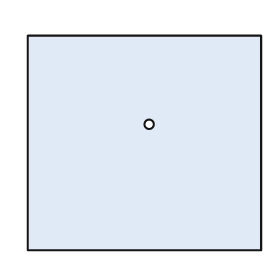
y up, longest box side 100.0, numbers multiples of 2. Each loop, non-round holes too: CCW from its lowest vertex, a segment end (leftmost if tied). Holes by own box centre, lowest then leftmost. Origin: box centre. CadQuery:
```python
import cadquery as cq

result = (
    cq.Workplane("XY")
    .moveTo(-50.0, -46.0)
    .lineTo(50.0, -46.0)
    .lineTo(50.0, 46.0)
    .lineTo(-50.0, 46.0)
    .close()
    .moveTo(2.0, 8.0)
    .circle(2.0)
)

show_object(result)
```